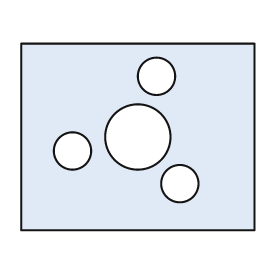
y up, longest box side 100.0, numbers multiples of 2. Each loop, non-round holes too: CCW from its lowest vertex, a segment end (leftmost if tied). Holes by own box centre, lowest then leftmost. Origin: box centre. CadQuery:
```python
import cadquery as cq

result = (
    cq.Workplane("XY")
    .moveTo(-50.0, -40.0)
    .lineTo(50.0, -40.0)
    .lineTo(50.0, 40.0)
    .lineTo(-50.0, 40.0)
    .close()
    .moveTo(18.0, -20.0)
    .circle(8.0)
    .moveTo(-28.0, -6.0)
    .circle(8.0)
    .moveTo(0.0, 0.0)
    .circle(14.0)
    .moveTo(8.0, 26.0)
    .circle(8.0)
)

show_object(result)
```